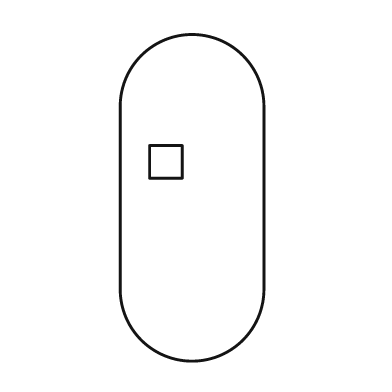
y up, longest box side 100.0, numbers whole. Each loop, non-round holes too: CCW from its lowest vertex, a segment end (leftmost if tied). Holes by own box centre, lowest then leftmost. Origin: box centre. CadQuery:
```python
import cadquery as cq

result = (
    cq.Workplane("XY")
    .moveTo(-22.0, -28.0)
    .threePointArc((0.0, -50.0), (22.0, -28.0))
    .lineTo(22.0, 28.0)
    .threePointArc((0.0, 50.0), (-22.0, 28.0))
    .close()
    .moveTo(-13.0, 6.0)
    .lineTo(-3.0, 6.0)
    .lineTo(-3.0, 16.0)
    .lineTo(-13.0, 16.0)
    .close()
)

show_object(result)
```